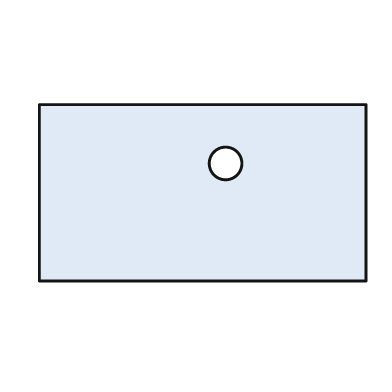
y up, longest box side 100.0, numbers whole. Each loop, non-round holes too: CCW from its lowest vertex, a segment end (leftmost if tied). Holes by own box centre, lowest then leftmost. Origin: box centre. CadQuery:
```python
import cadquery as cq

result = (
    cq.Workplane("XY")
    .moveTo(-50.0, -27.0)
    .lineTo(50.0, -27.0)
    .lineTo(50.0, 27.0)
    .lineTo(-50.0, 27.0)
    .close()
    .moveTo(7.0, 9.0)
    .circle(5.0)
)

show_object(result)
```